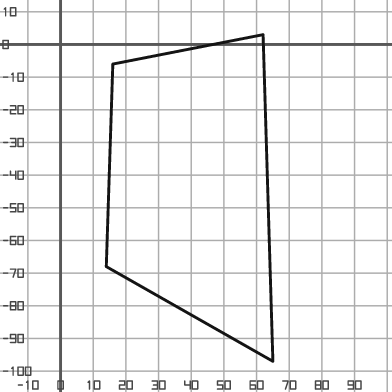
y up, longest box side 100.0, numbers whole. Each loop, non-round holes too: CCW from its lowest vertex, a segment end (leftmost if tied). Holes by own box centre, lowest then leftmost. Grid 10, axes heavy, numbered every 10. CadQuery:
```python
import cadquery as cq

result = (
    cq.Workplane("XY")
    .moveTo(65.0, -97.0)
    .lineTo(62.0, 3.0)
    .lineTo(16.0, -6.0)
    .lineTo(14.0, -68.0)
    .close()
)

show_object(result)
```